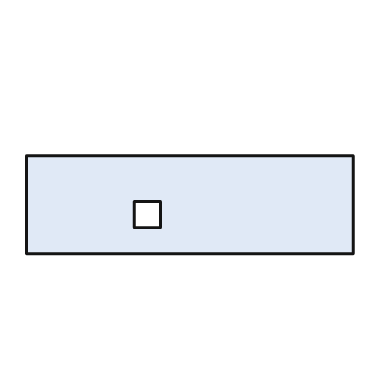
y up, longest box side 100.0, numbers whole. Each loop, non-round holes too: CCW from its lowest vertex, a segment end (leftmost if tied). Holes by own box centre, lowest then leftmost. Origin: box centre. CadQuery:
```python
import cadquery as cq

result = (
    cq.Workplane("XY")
    .moveTo(-50.0, -15.0)
    .lineTo(50.0, -15.0)
    .lineTo(50.0, 15.0)
    .lineTo(-50.0, 15.0)
    .close()
    .moveTo(-17.0, -7.0)
    .lineTo(-9.0, -7.0)
    .lineTo(-9.0, 1.0)
    .lineTo(-17.0, 1.0)
    .close()
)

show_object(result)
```